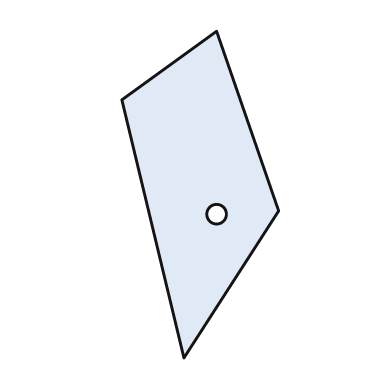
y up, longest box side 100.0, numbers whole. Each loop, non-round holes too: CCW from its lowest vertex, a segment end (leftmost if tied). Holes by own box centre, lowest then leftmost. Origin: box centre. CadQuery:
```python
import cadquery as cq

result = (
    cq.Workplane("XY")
    .moveTo(-5.0, -50.0)
    .lineTo(24.0, -5.0)
    .lineTo(5.0, 50.0)
    .lineTo(-24.0, 29.0)
    .close()
    .moveTo(5.0, -6.0)
    .circle(3.0)
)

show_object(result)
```